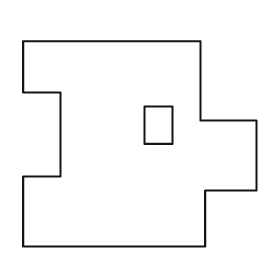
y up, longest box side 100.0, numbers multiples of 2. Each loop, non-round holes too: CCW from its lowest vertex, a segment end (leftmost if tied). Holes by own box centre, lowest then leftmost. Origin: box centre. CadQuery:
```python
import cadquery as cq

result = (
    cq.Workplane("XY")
    .moveTo(-50.0, -44.0)
    .lineTo(28.0, -44.0)
    .lineTo(28.0, -20.0)
    .lineTo(50.0, -20.0)
    .lineTo(50.0, 10.0)
    .lineTo(26.0, 10.0)
    .lineTo(26.0, 44.0)
    .lineTo(-50.0, 44.0)
    .lineTo(-50.0, 22.0)
    .lineTo(-34.0, 22.0)
    .lineTo(-34.0, -14.0)
    .lineTo(-50.0, -14.0)
    .close()
    .moveTo(2.0, 0.0)
    .lineTo(14.0, 0.0)
    .lineTo(14.0, 16.0)
    .lineTo(2.0, 16.0)
    .close()
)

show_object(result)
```